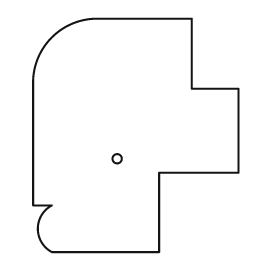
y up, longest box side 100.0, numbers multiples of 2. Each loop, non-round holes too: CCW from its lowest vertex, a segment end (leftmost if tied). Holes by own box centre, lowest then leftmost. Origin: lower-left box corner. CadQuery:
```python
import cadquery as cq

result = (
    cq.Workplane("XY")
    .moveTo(8.0, 0.0)
    .lineTo(54.0, 0.0)
    .lineTo(54.0, 34.0)
    .lineTo(88.0, 34.0)
    .lineTo(88.0, 70.0)
    .lineTo(68.0, 70.0)
    .lineTo(68.0, 100.0)
    .lineTo(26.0, 100.0)
    .threePointArc((8.0, 92.0), (0.0, 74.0))
    .lineTo(0.0, 20.0)
    .lineTo(8.0, 20.0)
    .threePointArc((2.0, 10.0), (8.0, 0.0))
    .close()
    .moveTo(36.0, 40.0)
    .circle(2.0)
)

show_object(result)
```